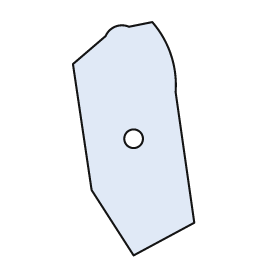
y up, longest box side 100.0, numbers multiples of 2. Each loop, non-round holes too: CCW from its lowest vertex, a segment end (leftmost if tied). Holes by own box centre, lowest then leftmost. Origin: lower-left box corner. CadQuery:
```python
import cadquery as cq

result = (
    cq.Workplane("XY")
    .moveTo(26.0, 0.0)
    .lineTo(52.0, 14.0)
    .lineTo(44.0, 70.0)
    .threePointArc((42.0, 86.0), (34.0, 100.0))
    .lineTo(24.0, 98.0)
    .threePointArc((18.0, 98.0), (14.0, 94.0))
    .lineTo(0.0, 82.0)
    .lineTo(8.0, 28.0)
    .close()
    .moveTo(26.0, 50.0)
    .circle(4.0)
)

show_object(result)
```